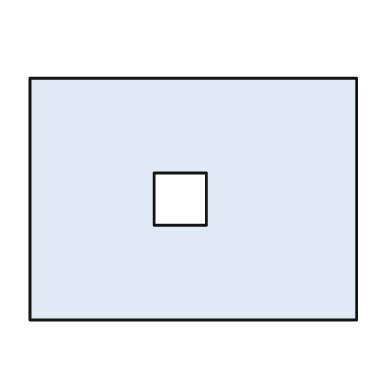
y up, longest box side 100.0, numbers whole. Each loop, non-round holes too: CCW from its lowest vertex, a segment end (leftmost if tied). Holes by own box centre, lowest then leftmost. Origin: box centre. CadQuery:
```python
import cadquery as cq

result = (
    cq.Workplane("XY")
    .moveTo(-50.0, -37.0)
    .lineTo(50.0, -37.0)
    .lineTo(50.0, 37.0)
    .lineTo(-50.0, 37.0)
    .close()
    .moveTo(-12.0, -8.0)
    .lineTo(4.0, -8.0)
    .lineTo(4.0, 8.0)
    .lineTo(-12.0, 8.0)
    .close()
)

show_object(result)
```